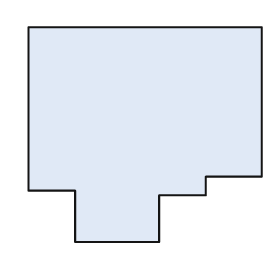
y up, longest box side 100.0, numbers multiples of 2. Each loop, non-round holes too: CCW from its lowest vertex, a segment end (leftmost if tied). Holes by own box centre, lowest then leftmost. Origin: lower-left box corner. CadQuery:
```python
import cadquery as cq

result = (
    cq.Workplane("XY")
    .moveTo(20.0, 0.0)
    .lineTo(56.0, 0.0)
    .lineTo(56.0, 20.0)
    .lineTo(76.0, 20.0)
    .lineTo(76.0, 28.0)
    .lineTo(100.0, 28.0)
    .lineTo(100.0, 92.0)
    .lineTo(0.0, 92.0)
    .lineTo(0.0, 22.0)
    .lineTo(20.0, 22.0)
    .close()
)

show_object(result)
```